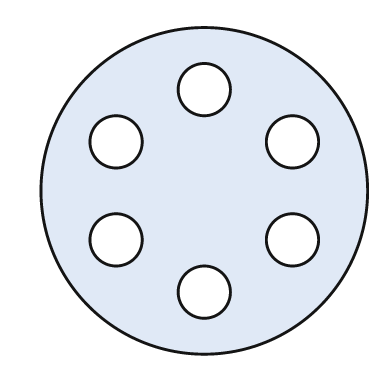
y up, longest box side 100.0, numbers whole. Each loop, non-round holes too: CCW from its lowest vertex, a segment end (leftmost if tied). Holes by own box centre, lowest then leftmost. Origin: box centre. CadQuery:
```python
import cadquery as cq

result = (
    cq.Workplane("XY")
    .moveTo(0.0, 0.0)
    .circle(50.0)
    .moveTo(0.0, -31.0)
    .circle(8.0)
    .moveTo(-27.0, -15.0)
    .circle(8.0)
    .moveTo(27.0, -15.0)
    .circle(8.0)
    .moveTo(-27.0, 15.0)
    .circle(8.0)
    .moveTo(27.0, 15.0)
    .circle(8.0)
    .moveTo(0.0, 31.0)
    .circle(8.0)
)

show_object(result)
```